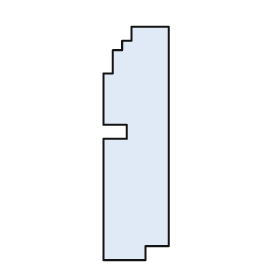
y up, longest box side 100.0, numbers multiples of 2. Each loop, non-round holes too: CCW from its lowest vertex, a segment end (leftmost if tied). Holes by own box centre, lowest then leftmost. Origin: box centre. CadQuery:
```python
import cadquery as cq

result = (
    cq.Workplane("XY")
    .moveTo(-14.0, -50.0)
    .lineTo(4.0, -50.0)
    .lineTo(4.0, -44.0)
    .lineTo(14.0, -44.0)
    .lineTo(14.0, 50.0)
    .lineTo(-2.0, 50.0)
    .lineTo(-2.0, 44.0)
    .lineTo(-6.0, 44.0)
    .lineTo(-6.0, 40.0)
    .lineTo(-10.0, 40.0)
    .lineTo(-10.0, 30.0)
    .lineTo(-14.0, 30.0)
    .lineTo(-14.0, 8.0)
    .lineTo(-4.0, 8.0)
    .lineTo(-4.0, 2.0)
    .lineTo(-14.0, 2.0)
    .close()
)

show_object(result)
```